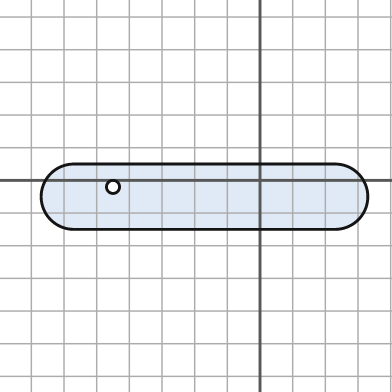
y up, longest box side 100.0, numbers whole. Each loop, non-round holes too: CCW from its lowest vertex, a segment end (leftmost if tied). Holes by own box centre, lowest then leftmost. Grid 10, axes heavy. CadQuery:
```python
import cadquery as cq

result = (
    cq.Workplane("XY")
    .moveTo(-57.0, -15.0)
    .lineTo(23.0, -15.0)
    .threePointArc((33.0, -5.0), (23.0, 5.0))
    .lineTo(-57.0, 5.0)
    .threePointArc((-67.0, -5.0), (-57.0, -15.0))
    .close()
    .moveTo(-45.0, -2.0)
    .circle(2.0)
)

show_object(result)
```